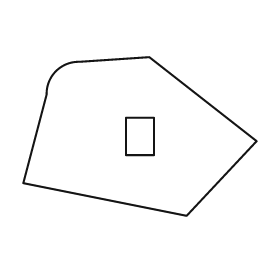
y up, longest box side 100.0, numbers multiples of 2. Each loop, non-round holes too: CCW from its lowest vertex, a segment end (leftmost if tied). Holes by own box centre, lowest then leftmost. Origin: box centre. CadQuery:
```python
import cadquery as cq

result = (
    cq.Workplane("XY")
    .moveTo(20.0, -34.0)
    .lineTo(50.0, -2.0)
    .lineTo(4.0, 34.0)
    .lineTo(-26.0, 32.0)
    .threePointArc((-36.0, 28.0), (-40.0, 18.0))
    .lineTo(-50.0, -20.0)
    .close()
    .moveTo(-6.0, -8.0)
    .lineTo(6.0, -8.0)
    .lineTo(6.0, 8.0)
    .lineTo(-6.0, 8.0)
    .close()
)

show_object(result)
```